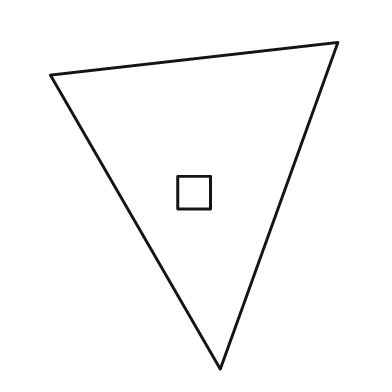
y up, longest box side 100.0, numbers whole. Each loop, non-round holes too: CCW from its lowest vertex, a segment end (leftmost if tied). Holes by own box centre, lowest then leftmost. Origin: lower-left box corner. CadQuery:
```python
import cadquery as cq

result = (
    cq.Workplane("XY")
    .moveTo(52.0, 0.0)
    .lineTo(88.0, 100.0)
    .lineTo(0.0, 90.0)
    .close()
    .moveTo(39.0, 49.0)
    .lineTo(49.0, 49.0)
    .lineTo(49.0, 59.0)
    .lineTo(39.0, 59.0)
    .close()
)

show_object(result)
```